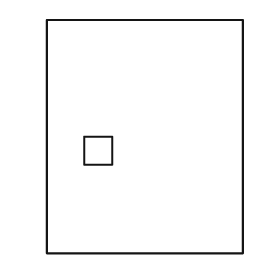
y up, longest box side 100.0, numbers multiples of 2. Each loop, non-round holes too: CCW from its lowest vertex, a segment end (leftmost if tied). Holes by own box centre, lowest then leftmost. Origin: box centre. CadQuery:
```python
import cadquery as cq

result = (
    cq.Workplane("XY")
    .moveTo(-42.0, -50.0)
    .lineTo(42.0, -50.0)
    .lineTo(42.0, 50.0)
    .lineTo(-42.0, 50.0)
    .close()
    .moveTo(-26.0, -12.0)
    .lineTo(-14.0, -12.0)
    .lineTo(-14.0, 0.0)
    .lineTo(-26.0, 0.0)
    .close()
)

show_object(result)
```